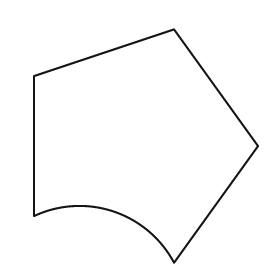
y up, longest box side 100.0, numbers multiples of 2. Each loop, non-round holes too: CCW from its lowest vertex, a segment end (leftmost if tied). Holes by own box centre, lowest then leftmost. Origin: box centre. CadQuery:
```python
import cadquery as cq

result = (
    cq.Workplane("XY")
    .moveTo(12.0, -50.0)
    .lineTo(48.0, 0.0)
    .lineTo(12.0, 50.0)
    .lineTo(-48.0, 30.0)
    .lineTo(-48.0, -30.0)
    .threePointArc((-14.0, -28.0), (12.0, -50.0))
    .close()
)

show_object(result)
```